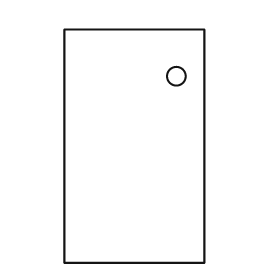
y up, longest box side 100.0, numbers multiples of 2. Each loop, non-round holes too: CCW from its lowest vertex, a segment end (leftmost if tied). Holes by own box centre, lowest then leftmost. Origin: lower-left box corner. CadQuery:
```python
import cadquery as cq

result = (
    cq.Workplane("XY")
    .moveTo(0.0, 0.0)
    .lineTo(60.0, 0.0)
    .lineTo(60.0, 100.0)
    .lineTo(0.0, 100.0)
    .close()
    .moveTo(48.0, 80.0)
    .circle(4.0)
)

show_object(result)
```